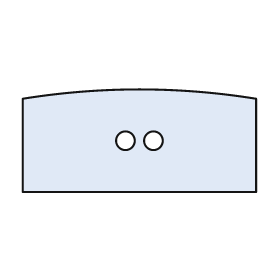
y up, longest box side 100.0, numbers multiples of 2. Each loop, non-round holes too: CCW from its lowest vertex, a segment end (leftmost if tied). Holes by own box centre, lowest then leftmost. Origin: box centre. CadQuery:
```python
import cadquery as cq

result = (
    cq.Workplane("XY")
    .moveTo(-50.0, -22.0)
    .lineTo(50.0, -22.0)
    .lineTo(50.0, 18.0)
    .threePointArc((0.0, 22.0), (-50.0, 18.0))
    .close()
    .moveTo(-6.0, 0.0)
    .circle(4.0)
    .moveTo(6.0, 0.0)
    .circle(4.0)
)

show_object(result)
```